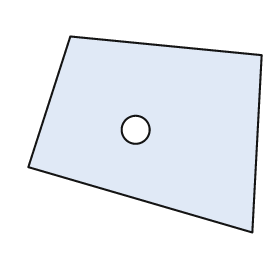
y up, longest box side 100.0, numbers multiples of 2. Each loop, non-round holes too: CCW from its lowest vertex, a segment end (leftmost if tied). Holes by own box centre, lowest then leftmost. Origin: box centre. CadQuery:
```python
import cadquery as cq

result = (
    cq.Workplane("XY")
    .moveTo(46.0, -42.0)
    .lineTo(50.0, 34.0)
    .lineTo(-32.0, 42.0)
    .lineTo(-50.0, -14.0)
    .close()
    .moveTo(-4.0, 2.0)
    .circle(6.0)
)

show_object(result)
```